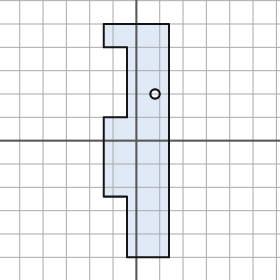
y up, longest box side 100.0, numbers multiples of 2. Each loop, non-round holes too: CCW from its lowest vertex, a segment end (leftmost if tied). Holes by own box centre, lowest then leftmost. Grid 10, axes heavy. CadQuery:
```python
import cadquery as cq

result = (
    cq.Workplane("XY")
    .moveTo(-4.0, -50.0)
    .lineTo(14.0, -50.0)
    .lineTo(14.0, 50.0)
    .lineTo(-14.0, 50.0)
    .lineTo(-14.0, 40.0)
    .lineTo(-4.0, 40.0)
    .lineTo(-4.0, 10.0)
    .lineTo(-14.0, 10.0)
    .lineTo(-14.0, -24.0)
    .lineTo(-4.0, -24.0)
    .close()
    .moveTo(8.0, 20.0)
    .circle(2.0)
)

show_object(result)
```